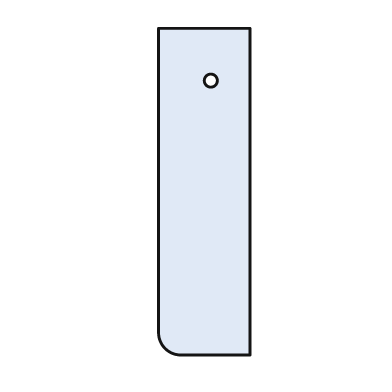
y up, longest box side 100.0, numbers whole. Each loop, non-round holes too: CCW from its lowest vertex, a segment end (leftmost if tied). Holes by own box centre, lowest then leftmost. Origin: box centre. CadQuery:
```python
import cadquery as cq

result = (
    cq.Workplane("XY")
    .moveTo(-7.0, -50.0)
    .lineTo(14.0, -50.0)
    .lineTo(14.0, 50.0)
    .lineTo(-14.0, 50.0)
    .lineTo(-14.0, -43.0)
    .threePointArc((-12.0, -48.0), (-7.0, -50.0))
    .close()
    .moveTo(2.0, 34.0)
    .circle(2.0)
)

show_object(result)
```